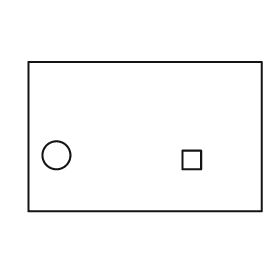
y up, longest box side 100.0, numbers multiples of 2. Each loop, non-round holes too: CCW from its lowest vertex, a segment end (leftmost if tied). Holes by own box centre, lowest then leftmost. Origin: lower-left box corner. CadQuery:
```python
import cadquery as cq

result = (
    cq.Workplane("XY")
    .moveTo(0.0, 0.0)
    .lineTo(100.0, 0.0)
    .lineTo(100.0, 64.0)
    .lineTo(0.0, 64.0)
    .close()
    .moveTo(66.0, 18.0)
    .lineTo(74.0, 18.0)
    .lineTo(74.0, 26.0)
    .lineTo(66.0, 26.0)
    .close()
    .moveTo(12.0, 24.0)
    .circle(6.0)
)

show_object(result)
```